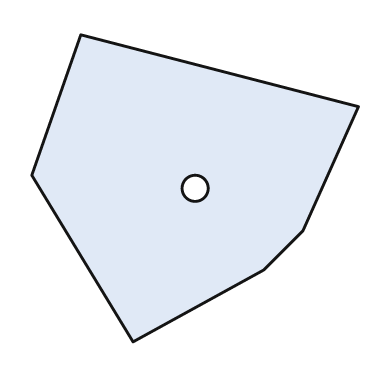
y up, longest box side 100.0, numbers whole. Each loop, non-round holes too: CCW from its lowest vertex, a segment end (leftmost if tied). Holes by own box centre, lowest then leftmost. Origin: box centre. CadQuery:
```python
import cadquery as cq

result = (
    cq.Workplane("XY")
    .moveTo(-19.0, -47.0)
    .lineTo(21.0, -25.0)
    .lineTo(33.0, -13.0)
    .lineTo(50.0, 25.0)
    .lineTo(-35.0, 47.0)
    .lineTo(-50.0, 4.0)
    .close()
    .moveTo(0.0, 0.0)
    .circle(4.0)
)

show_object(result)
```